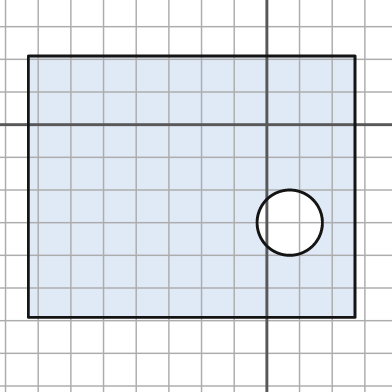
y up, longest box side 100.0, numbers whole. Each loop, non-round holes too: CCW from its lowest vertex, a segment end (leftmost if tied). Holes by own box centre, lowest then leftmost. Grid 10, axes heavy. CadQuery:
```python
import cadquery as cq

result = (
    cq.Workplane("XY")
    .moveTo(-73.0, -59.0)
    .lineTo(27.0, -59.0)
    .lineTo(27.0, 21.0)
    .lineTo(-73.0, 21.0)
    .close()
    .moveTo(7.0, -30.0)
    .circle(10.0)
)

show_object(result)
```